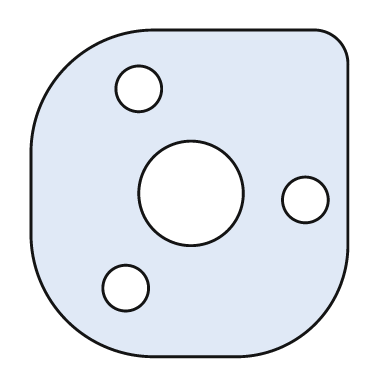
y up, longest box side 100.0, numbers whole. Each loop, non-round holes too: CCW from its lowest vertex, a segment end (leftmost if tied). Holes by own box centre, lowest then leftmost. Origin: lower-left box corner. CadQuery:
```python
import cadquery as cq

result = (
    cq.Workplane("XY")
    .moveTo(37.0, 0.0)
    .lineTo(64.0, 0.0)
    .threePointArc((87.0, 10.0), (97.0, 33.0))
    .lineTo(97.0, 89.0)
    .threePointArc((94.0, 97.0), (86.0, 100.0))
    .lineTo(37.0, 100.0)
    .threePointArc((11.0, 89.0), (0.0, 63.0))
    .lineTo(0.0, 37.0)
    .threePointArc((11.0, 11.0), (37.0, 0.0))
    .close()
    .moveTo(29.0, 21.0)
    .circle(7.0)
    .moveTo(84.0, 48.0)
    .circle(7.0)
    .moveTo(49.0, 50.0)
    .circle(16.0)
    .moveTo(33.0, 82.0)
    .circle(7.0)
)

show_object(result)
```